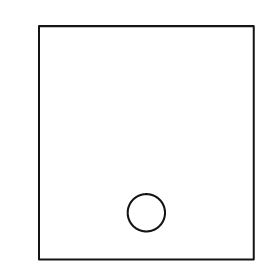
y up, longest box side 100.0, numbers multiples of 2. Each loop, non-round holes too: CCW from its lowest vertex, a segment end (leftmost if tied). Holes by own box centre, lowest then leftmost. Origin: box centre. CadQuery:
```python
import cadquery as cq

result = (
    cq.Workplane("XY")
    .moveTo(-46.0, -50.0)
    .lineTo(46.0, -50.0)
    .lineTo(46.0, 50.0)
    .lineTo(-46.0, 50.0)
    .close()
    .moveTo(0.0, -30.0)
    .circle(8.0)
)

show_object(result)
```